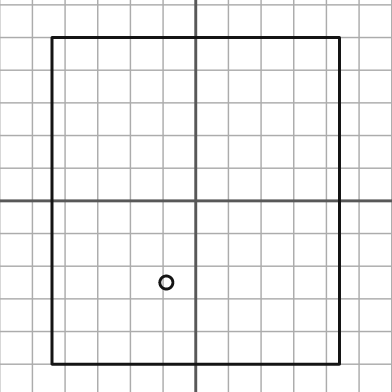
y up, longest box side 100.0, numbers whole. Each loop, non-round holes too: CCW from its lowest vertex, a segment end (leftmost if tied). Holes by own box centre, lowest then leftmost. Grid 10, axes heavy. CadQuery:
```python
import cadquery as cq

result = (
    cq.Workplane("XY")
    .moveTo(-44.0, -50.0)
    .lineTo(44.0, -50.0)
    .lineTo(44.0, 50.0)
    .lineTo(-44.0, 50.0)
    .close()
    .moveTo(-9.0, -25.0)
    .circle(2.0)
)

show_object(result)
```